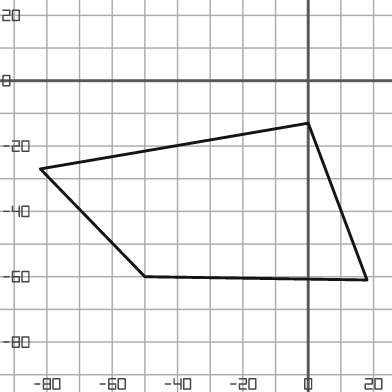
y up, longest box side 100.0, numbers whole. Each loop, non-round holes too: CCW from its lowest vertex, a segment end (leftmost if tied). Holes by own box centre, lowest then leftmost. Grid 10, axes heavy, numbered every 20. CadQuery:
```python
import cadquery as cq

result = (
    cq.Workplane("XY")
    .moveTo(18.0, -61.0)
    .lineTo(0.0, -13.0)
    .lineTo(-82.0, -27.0)
    .lineTo(-50.0, -60.0)
    .close()
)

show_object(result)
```